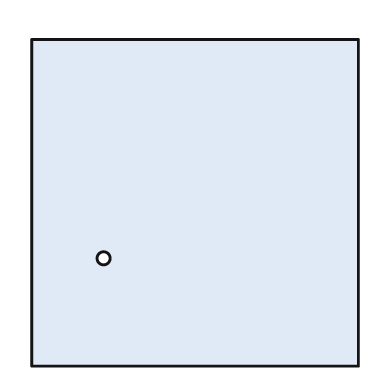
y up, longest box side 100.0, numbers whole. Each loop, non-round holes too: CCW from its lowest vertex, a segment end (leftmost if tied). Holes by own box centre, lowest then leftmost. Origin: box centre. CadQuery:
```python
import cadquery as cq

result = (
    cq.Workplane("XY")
    .moveTo(-50.0, -50.0)
    .lineTo(50.0, -50.0)
    .lineTo(50.0, 50.0)
    .lineTo(-50.0, 50.0)
    .close()
    .moveTo(-28.0, -17.0)
    .circle(2.0)
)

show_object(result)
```